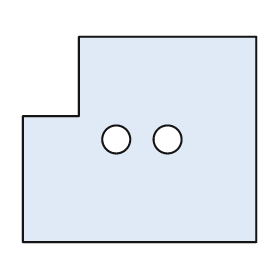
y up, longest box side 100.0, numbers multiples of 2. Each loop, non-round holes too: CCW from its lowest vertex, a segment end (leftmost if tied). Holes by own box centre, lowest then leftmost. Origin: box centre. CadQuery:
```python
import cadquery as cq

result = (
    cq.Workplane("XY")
    .moveTo(-50.0, -44.0)
    .lineTo(50.0, -44.0)
    .lineTo(50.0, 44.0)
    .lineTo(-26.0, 44.0)
    .lineTo(-26.0, 10.0)
    .lineTo(-50.0, 10.0)
    .close()
    .moveTo(-10.0, 0.0)
    .circle(6.0)
    .moveTo(12.0, 0.0)
    .circle(6.0)
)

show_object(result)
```